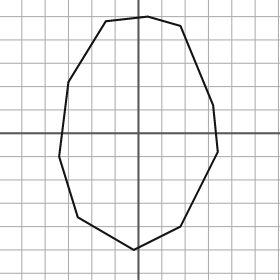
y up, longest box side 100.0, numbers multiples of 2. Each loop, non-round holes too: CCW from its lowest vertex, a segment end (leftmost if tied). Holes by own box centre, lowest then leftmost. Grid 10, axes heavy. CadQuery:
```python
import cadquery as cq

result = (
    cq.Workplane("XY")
    .moveTo(-2.0, -50.0)
    .lineTo(18.0, -40.0)
    .lineTo(34.0, -8.0)
    .lineTo(32.0, 12.0)
    .lineTo(18.0, 46.0)
    .lineTo(4.0, 50.0)
    .lineTo(-14.0, 48.0)
    .lineTo(-30.0, 22.0)
    .lineTo(-34.0, -10.0)
    .lineTo(-26.0, -36.0)
    .close()
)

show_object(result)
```